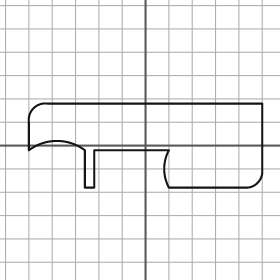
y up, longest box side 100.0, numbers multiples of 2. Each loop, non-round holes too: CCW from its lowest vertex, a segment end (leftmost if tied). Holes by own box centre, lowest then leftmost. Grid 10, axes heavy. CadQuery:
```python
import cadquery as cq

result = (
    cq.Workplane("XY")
    .moveTo(-26.0, -18.0)
    .lineTo(-22.0, -18.0)
    .lineTo(-22.0, -2.0)
    .lineTo(10.0, -2.0)
    .threePointArc((8.0, -10.0), (10.0, -18.0))
    .lineTo(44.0, -18.0)
    .threePointArc((48.0, -16.0), (50.0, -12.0))
    .lineTo(50.0, 18.0)
    .lineTo(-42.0, 18.0)
    .threePointArc((-48.0, 16.0), (-50.0, 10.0))
    .lineTo(-50.0, -2.0)
    .threePointArc((-38.0, 2.0), (-26.0, -2.0))
    .close()
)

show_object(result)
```